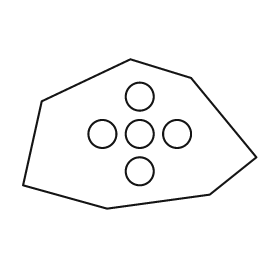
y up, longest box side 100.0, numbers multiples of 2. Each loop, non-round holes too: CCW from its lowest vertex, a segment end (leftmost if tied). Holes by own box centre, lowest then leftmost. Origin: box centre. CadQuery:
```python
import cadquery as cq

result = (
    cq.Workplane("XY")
    .moveTo(-14.0, -32.0)
    .lineTo(30.0, -26.0)
    .lineTo(50.0, -10.0)
    .lineTo(22.0, 24.0)
    .lineTo(-4.0, 32.0)
    .lineTo(-42.0, 14.0)
    .lineTo(-50.0, -22.0)
    .close()
    .moveTo(0.0, -16.0)
    .circle(6.0)
    .moveTo(-16.0, 0.0)
    .circle(6.0)
    .moveTo(0.0, 0.0)
    .circle(6.0)
    .moveTo(16.0, 0.0)
    .circle(6.0)
    .moveTo(0.0, 16.0)
    .circle(6.0)
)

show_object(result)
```